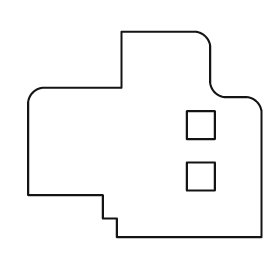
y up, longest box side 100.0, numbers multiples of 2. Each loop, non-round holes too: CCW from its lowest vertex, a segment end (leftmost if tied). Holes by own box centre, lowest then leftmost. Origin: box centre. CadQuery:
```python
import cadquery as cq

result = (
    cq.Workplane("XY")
    .moveTo(-12.0, -44.0)
    .lineTo(50.0, -44.0)
    .lineTo(50.0, 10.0)
    .threePointArc((48.0, 14.0), (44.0, 16.0))
    .lineTo(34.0, 16.0)
    .threePointArc((30.0, 18.0), (28.0, 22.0))
    .lineTo(28.0, 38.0)
    .threePointArc((26.0, 42.0), (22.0, 44.0))
    .lineTo(-10.0, 44.0)
    .lineTo(-10.0, 20.0)
    .lineTo(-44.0, 20.0)
    .threePointArc((-48.0, 18.0), (-50.0, 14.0))
    .lineTo(-50.0, -26.0)
    .lineTo(-18.0, -26.0)
    .lineTo(-18.0, -36.0)
    .lineTo(-12.0, -36.0)
    .close()
    .moveTo(18.0, -24.0)
    .lineTo(30.0, -24.0)
    .lineTo(30.0, -12.0)
    .lineTo(18.0, -12.0)
    .close()
    .moveTo(18.0, -2.0)
    .lineTo(30.0, -2.0)
    .lineTo(30.0, 10.0)
    .lineTo(18.0, 10.0)
    .close()
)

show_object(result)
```